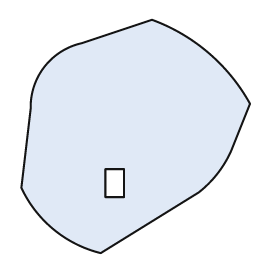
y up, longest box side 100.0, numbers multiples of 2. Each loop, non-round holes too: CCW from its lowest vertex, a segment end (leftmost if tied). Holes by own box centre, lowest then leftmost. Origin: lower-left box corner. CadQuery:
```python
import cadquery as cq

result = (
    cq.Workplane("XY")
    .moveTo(34.0, 0.0)
    .lineTo(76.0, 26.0)
    .threePointArc((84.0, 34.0), (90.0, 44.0))
    .lineTo(98.0, 64.0)
    .threePointArc((80.0, 86.0), (56.0, 100.0))
    .lineTo(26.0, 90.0)
    .threePointArc((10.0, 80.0), (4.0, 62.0))
    .lineTo(0.0, 28.0)
    .threePointArc((14.0, 10.0), (34.0, 0.0))
    .close()
    .moveTo(36.0, 24.0)
    .lineTo(44.0, 24.0)
    .lineTo(44.0, 36.0)
    .lineTo(36.0, 36.0)
    .close()
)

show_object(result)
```